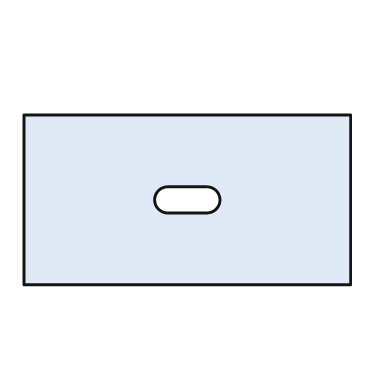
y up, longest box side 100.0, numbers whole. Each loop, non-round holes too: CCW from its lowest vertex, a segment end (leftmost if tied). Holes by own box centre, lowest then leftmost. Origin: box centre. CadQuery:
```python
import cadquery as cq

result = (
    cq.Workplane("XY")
    .moveTo(-50.0, -26.0)
    .lineTo(50.0, -26.0)
    .lineTo(50.0, 26.0)
    .lineTo(-50.0, 26.0)
    .close()
    .moveTo(-6.0, -4.0)
    .lineTo(6.0, -4.0)
    .threePointArc((10.0, 0.0), (6.0, 4.0))
    .lineTo(-6.0, 4.0)
    .threePointArc((-10.0, 0.0), (-6.0, -4.0))
    .close()
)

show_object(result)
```